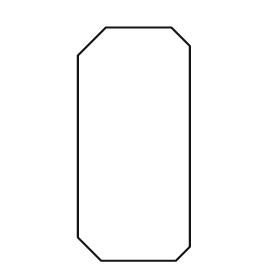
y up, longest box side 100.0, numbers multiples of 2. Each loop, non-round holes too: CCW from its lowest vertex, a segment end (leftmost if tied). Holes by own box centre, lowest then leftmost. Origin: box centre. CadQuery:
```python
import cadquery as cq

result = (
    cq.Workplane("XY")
    .moveTo(-14.0, -50.0)
    .lineTo(18.0, -50.0)
    .lineTo(24.0, -44.0)
    .lineTo(24.0, 42.0)
    .lineTo(16.0, 50.0)
    .lineTo(-12.0, 50.0)
    .lineTo(-24.0, 38.0)
    .lineTo(-24.0, -40.0)
    .close()
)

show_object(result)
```